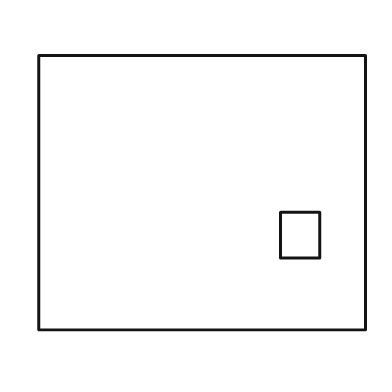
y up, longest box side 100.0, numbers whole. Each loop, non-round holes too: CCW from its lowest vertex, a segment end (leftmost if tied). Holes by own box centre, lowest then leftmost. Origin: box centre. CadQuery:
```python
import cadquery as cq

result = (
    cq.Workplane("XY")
    .moveTo(-50.0, -42.0)
    .lineTo(50.0, -42.0)
    .lineTo(50.0, 42.0)
    .lineTo(-50.0, 42.0)
    .close()
    .moveTo(24.0, -20.0)
    .lineTo(36.0, -20.0)
    .lineTo(36.0, -6.0)
    .lineTo(24.0, -6.0)
    .close()
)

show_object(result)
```